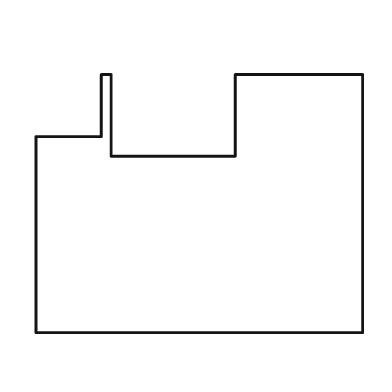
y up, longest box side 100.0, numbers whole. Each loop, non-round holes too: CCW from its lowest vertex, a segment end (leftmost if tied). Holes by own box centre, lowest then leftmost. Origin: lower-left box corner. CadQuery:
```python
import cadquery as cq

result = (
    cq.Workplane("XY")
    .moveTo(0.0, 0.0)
    .lineTo(100.0, 0.0)
    .lineTo(100.0, 79.0)
    .lineTo(61.0, 79.0)
    .lineTo(61.0, 54.0)
    .lineTo(23.0, 54.0)
    .lineTo(23.0, 79.0)
    .lineTo(20.0, 79.0)
    .lineTo(20.0, 60.0)
    .lineTo(0.0, 60.0)
    .close()
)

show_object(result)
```